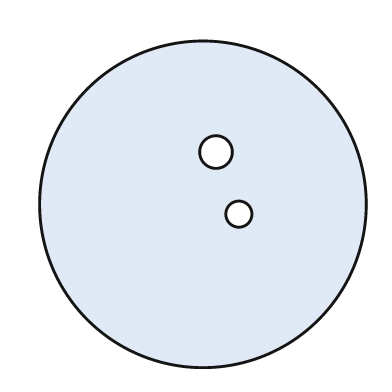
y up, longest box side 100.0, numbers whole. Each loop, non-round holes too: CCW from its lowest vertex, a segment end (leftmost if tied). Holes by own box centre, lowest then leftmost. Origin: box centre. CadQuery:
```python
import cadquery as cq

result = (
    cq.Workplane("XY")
    .moveTo(0.0, 0.0)
    .circle(50.0)
    .moveTo(11.0, -3.0)
    .circle(4.0)
    .moveTo(4.0, 16.0)
    .circle(5.0)
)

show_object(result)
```